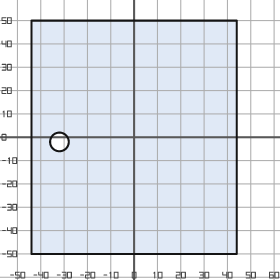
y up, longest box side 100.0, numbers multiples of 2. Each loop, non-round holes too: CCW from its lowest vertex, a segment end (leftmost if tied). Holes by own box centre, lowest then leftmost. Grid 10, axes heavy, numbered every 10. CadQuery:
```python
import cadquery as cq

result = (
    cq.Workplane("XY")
    .moveTo(-44.0, -50.0)
    .lineTo(44.0, -50.0)
    .lineTo(44.0, 50.0)
    .lineTo(-44.0, 50.0)
    .close()
    .moveTo(-32.0, -2.0)
    .circle(4.0)
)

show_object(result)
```